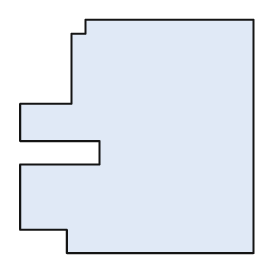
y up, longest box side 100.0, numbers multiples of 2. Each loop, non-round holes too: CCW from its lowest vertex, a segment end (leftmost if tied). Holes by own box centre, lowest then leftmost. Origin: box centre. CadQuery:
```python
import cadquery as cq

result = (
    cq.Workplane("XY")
    .moveTo(-30.0, -50.0)
    .lineTo(50.0, -50.0)
    .lineTo(50.0, 50.0)
    .lineTo(-22.0, 50.0)
    .lineTo(-22.0, 44.0)
    .lineTo(-28.0, 44.0)
    .lineTo(-28.0, 14.0)
    .lineTo(-50.0, 14.0)
    .lineTo(-50.0, -2.0)
    .lineTo(-16.0, -2.0)
    .lineTo(-16.0, -12.0)
    .lineTo(-50.0, -12.0)
    .lineTo(-50.0, -40.0)
    .lineTo(-30.0, -40.0)
    .close()
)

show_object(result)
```